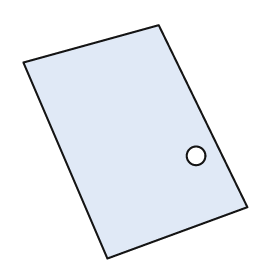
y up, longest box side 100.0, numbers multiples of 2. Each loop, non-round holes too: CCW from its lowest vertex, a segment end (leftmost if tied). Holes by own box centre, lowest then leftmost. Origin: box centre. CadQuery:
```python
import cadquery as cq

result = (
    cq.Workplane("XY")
    .moveTo(-12.0, -50.0)
    .lineTo(48.0, -28.0)
    .lineTo(10.0, 50.0)
    .lineTo(-48.0, 34.0)
    .close()
    .moveTo(26.0, -6.0)
    .circle(4.0)
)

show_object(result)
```